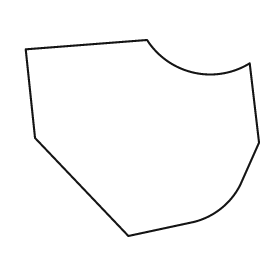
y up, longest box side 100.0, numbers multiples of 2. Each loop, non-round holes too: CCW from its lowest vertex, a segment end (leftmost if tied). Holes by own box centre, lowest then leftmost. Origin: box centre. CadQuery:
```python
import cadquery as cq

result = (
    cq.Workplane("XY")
    .moveTo(-6.0, -42.0)
    .lineTo(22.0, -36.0)
    .threePointArc((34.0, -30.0), (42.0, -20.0))
    .lineTo(50.0, -2.0)
    .lineTo(46.0, 32.0)
    .threePointArc((22.0, 28.0), (2.0, 42.0))
    .lineTo(-50.0, 38.0)
    .lineTo(-46.0, 0.0)
    .close()
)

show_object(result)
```